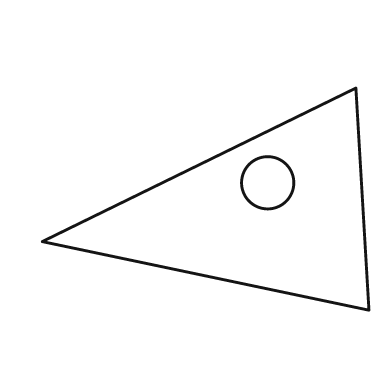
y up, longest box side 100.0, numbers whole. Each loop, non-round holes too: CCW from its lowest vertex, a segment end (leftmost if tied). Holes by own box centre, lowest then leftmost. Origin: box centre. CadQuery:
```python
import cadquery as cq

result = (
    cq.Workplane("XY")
    .moveTo(50.0, -34.0)
    .lineTo(46.0, 34.0)
    .lineTo(-50.0, -13.0)
    .close()
    .moveTo(19.0, 5.0)
    .circle(8.0)
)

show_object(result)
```